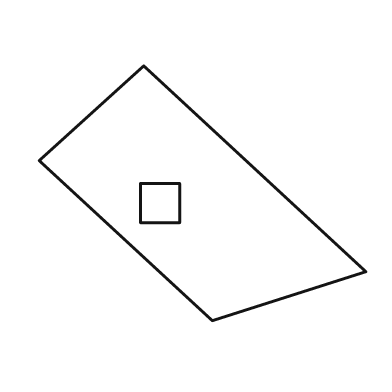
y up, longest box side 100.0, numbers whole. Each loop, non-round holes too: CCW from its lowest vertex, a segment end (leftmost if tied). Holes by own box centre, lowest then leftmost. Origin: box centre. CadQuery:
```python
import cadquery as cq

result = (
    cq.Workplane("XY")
    .moveTo(3.0, -39.0)
    .lineTo(50.0, -24.0)
    .lineTo(-18.0, 39.0)
    .lineTo(-50.0, 10.0)
    .close()
    .moveTo(-19.0, -9.0)
    .lineTo(-7.0, -9.0)
    .lineTo(-7.0, 3.0)
    .lineTo(-19.0, 3.0)
    .close()
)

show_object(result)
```